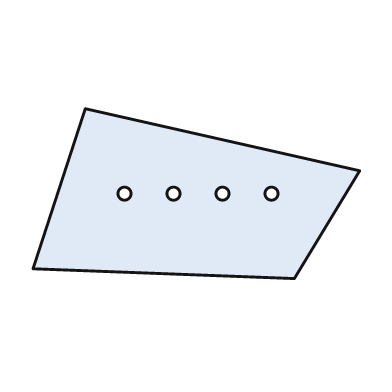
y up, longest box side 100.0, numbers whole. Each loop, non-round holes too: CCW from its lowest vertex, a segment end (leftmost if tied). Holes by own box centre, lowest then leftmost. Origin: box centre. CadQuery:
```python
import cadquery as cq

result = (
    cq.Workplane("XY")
    .moveTo(30.0, -26.0)
    .lineTo(50.0, 7.0)
    .lineTo(-34.0, 26.0)
    .lineTo(-50.0, -23.0)
    .close()
    .moveTo(-22.0, 0.0)
    .circle(2.0)
    .moveTo(-7.0, 0.0)
    .circle(2.0)
    .moveTo(8.0, 0.0)
    .circle(2.0)
    .moveTo(23.0, 0.0)
    .circle(2.0)
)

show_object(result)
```